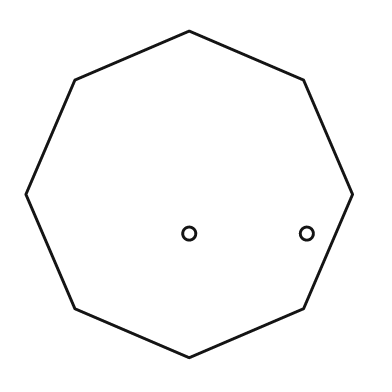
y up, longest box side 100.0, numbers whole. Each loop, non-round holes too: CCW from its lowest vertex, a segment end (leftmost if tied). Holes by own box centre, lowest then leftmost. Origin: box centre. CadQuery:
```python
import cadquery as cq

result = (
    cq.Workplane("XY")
    .moveTo(0.0, -50.0)
    .lineTo(35.0, -35.0)
    .lineTo(50.0, 0.0)
    .lineTo(35.0, 35.0)
    .lineTo(0.0, 50.0)
    .lineTo(-35.0, 35.0)
    .lineTo(-50.0, 0.0)
    .lineTo(-35.0, -35.0)
    .close()
    .moveTo(0.0, -12.0)
    .circle(2.0)
    .moveTo(36.0, -12.0)
    .circle(2.0)
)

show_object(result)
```